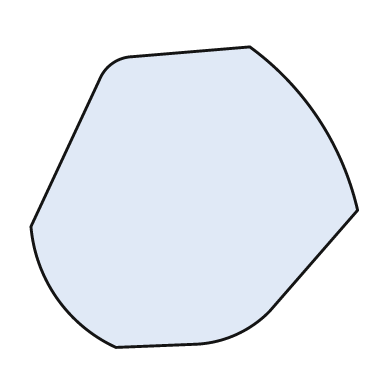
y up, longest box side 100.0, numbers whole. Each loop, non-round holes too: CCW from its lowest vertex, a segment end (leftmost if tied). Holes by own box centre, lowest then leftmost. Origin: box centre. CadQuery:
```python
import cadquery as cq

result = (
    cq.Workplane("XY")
    .moveTo(-24.0, -46.0)
    .lineTo(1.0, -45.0)
    .threePointArc((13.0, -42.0), (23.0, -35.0))
    .lineTo(50.0, -4.0)
    .threePointArc((38.0, 24.0), (17.0, 46.0))
    .lineTo(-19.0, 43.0)
    .threePointArc((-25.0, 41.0), (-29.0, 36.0))
    .lineTo(-50.0, -9.0)
    .threePointArc((-42.0, -31.0), (-24.0, -46.0))
    .close()
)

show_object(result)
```